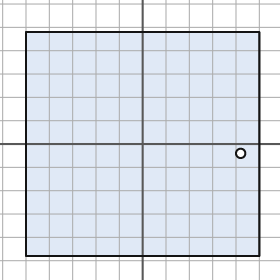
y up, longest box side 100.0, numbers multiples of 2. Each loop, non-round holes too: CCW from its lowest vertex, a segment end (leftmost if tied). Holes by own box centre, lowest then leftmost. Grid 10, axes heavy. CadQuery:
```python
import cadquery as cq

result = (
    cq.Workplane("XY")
    .moveTo(-50.0, -48.0)
    .lineTo(50.0, -48.0)
    .lineTo(50.0, 48.0)
    .lineTo(-50.0, 48.0)
    .close()
    .moveTo(42.0, -4.0)
    .circle(2.0)
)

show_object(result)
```